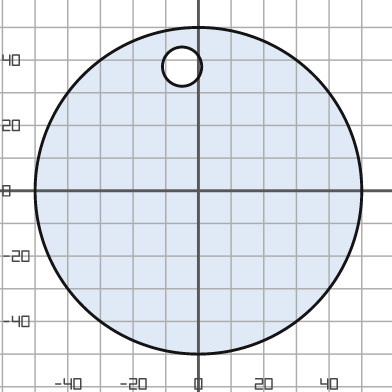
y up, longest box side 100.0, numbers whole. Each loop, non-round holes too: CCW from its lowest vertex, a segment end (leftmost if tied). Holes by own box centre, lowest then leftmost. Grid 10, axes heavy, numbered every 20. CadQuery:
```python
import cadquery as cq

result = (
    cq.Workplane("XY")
    .moveTo(0.0, 0.0)
    .circle(50.0)
    .moveTo(-5.0, 38.0)
    .circle(6.0)
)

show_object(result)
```